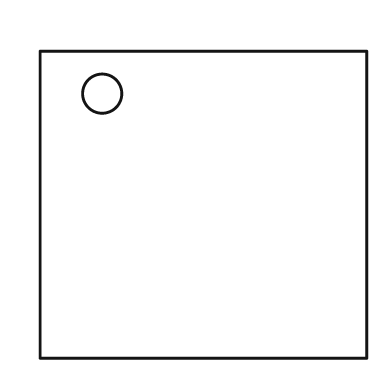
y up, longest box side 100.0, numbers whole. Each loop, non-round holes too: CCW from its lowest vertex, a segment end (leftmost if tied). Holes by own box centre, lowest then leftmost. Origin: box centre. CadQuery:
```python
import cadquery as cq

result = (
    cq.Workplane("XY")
    .moveTo(-50.0, -47.0)
    .lineTo(50.0, -47.0)
    .lineTo(50.0, 47.0)
    .lineTo(-50.0, 47.0)
    .close()
    .moveTo(-31.0, 34.0)
    .circle(6.0)
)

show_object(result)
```